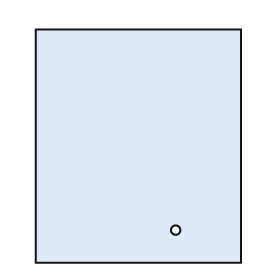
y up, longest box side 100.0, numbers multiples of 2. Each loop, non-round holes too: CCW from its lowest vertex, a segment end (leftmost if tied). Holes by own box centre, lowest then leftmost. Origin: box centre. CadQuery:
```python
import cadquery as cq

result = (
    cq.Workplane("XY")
    .moveTo(-44.0, -50.0)
    .lineTo(44.0, -50.0)
    .lineTo(44.0, 50.0)
    .lineTo(-44.0, 50.0)
    .close()
    .moveTo(16.0, -36.0)
    .circle(2.0)
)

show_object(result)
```